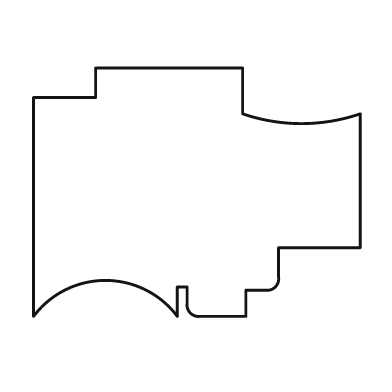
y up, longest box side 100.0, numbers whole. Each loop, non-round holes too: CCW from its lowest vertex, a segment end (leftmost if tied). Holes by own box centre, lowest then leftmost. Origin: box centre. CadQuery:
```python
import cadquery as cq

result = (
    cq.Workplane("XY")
    .moveTo(-50.0, -38.0)
    .threePointArc((-28.0, -27.0), (-6.0, -38.0))
    .lineTo(-6.0, -29.0)
    .lineTo(-3.0, -29.0)
    .lineTo(-3.0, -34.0)
    .threePointArc((-2.0, -37.0), (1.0, -38.0))
    .lineTo(15.0, -38.0)
    .lineTo(15.0, -30.0)
    .lineTo(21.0, -30.0)
    .threePointArc((24.0, -29.0), (25.0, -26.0))
    .lineTo(25.0, -17.0)
    .lineTo(50.0, -17.0)
    .lineTo(50.0, 24.0)
    .threePointArc((32.0, 21.0), (14.0, 24.0))
    .lineTo(14.0, 38.0)
    .lineTo(-31.0, 38.0)
    .lineTo(-31.0, 29.0)
    .lineTo(-50.0, 29.0)
    .close()
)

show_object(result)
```